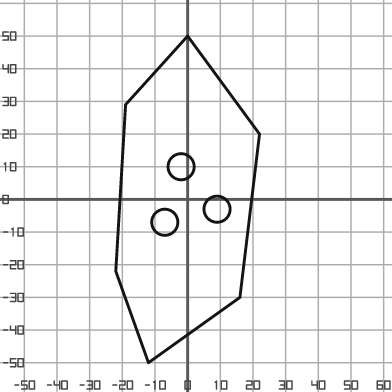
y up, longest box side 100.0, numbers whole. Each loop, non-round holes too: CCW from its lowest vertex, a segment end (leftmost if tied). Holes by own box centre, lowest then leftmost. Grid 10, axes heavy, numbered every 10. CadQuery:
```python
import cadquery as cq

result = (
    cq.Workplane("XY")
    .moveTo(-12.0, -50.0)
    .lineTo(16.0, -30.0)
    .lineTo(22.0, 20.0)
    .lineTo(0.0, 50.0)
    .lineTo(-19.0, 29.0)
    .lineTo(-22.0, -22.0)
    .close()
    .moveTo(-7.0, -7.0)
    .circle(4.0)
    .moveTo(9.0, -3.0)
    .circle(4.0)
    .moveTo(-2.0, 10.0)
    .circle(4.0)
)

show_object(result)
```